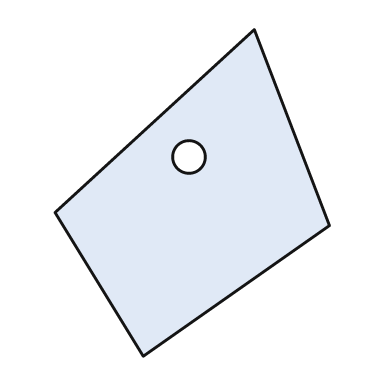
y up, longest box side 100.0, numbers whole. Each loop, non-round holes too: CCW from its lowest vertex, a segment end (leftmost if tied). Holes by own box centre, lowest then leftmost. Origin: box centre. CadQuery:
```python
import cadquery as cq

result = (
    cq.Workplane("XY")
    .moveTo(-15.0, -50.0)
    .lineTo(42.0, -10.0)
    .lineTo(19.0, 50.0)
    .lineTo(-42.0, -6.0)
    .close()
    .moveTo(-1.0, 11.0)
    .circle(5.0)
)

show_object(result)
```